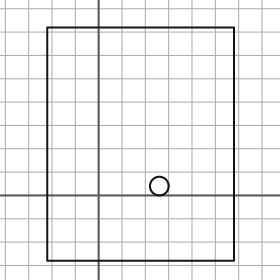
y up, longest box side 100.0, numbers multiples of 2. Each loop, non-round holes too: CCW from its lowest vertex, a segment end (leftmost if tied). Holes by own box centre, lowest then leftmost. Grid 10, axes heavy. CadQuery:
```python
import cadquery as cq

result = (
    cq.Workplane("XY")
    .moveTo(-22.0, -28.0)
    .lineTo(58.0, -28.0)
    .lineTo(58.0, 72.0)
    .lineTo(-22.0, 72.0)
    .close()
    .moveTo(26.0, 4.0)
    .circle(4.0)
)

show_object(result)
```